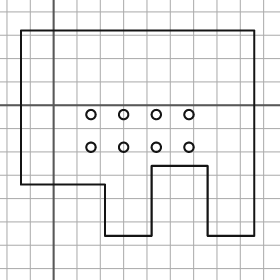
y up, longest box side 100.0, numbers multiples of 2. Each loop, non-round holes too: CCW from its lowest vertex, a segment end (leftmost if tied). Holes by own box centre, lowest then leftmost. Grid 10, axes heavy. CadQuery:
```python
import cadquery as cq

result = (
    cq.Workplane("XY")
    .moveTo(22.0, -56.0)
    .lineTo(42.0, -56.0)
    .lineTo(42.0, -26.0)
    .lineTo(66.0, -26.0)
    .lineTo(66.0, -56.0)
    .lineTo(86.0, -56.0)
    .lineTo(86.0, 32.0)
    .lineTo(-14.0, 32.0)
    .lineTo(-14.0, -34.0)
    .lineTo(22.0, -34.0)
    .close()
    .moveTo(16.0, -18.0)
    .circle(2.0)
    .moveTo(30.0, -18.0)
    .circle(2.0)
    .moveTo(44.0, -18.0)
    .circle(2.0)
    .moveTo(58.0, -18.0)
    .circle(2.0)
    .moveTo(16.0, -4.0)
    .circle(2.0)
    .moveTo(30.0, -4.0)
    .circle(2.0)
    .moveTo(44.0, -4.0)
    .circle(2.0)
    .moveTo(58.0, -4.0)
    .circle(2.0)
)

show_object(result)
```